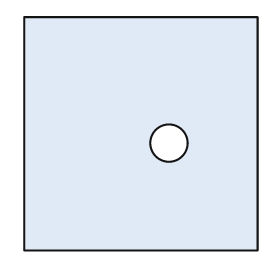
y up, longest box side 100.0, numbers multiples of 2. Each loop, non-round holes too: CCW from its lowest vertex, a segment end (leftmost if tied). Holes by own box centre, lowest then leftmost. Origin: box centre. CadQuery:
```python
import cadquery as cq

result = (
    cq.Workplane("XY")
    .moveTo(-50.0, -50.0)
    .lineTo(50.0, -50.0)
    .lineTo(50.0, 50.0)
    .lineTo(-50.0, 50.0)
    .close()
    .moveTo(12.0, -4.0)
    .circle(8.0)
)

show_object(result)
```